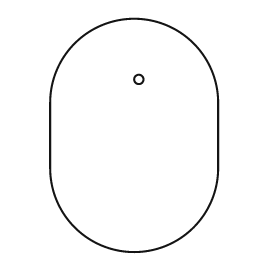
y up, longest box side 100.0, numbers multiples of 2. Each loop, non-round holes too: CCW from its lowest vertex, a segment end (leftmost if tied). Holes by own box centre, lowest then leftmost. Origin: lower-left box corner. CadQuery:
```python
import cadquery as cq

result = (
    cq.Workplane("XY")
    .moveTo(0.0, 36.0)
    .threePointArc((36.0, 0.0), (72.0, 36.0))
    .lineTo(72.0, 64.0)
    .threePointArc((36.0, 100.0), (0.0, 64.0))
    .close()
    .moveTo(38.0, 74.0)
    .circle(2.0)
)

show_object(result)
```